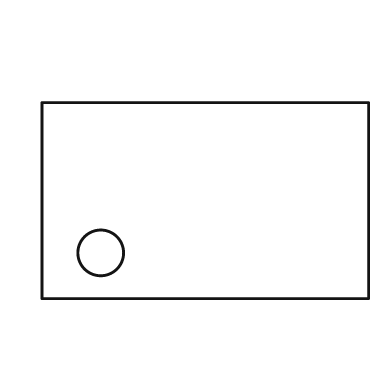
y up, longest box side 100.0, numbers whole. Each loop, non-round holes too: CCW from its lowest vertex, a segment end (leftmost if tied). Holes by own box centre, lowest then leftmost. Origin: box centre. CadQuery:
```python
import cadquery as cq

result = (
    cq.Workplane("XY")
    .moveTo(-50.0, -30.0)
    .lineTo(50.0, -30.0)
    .lineTo(50.0, 30.0)
    .lineTo(-50.0, 30.0)
    .close()
    .moveTo(-32.0, -16.0)
    .circle(7.0)
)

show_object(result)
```